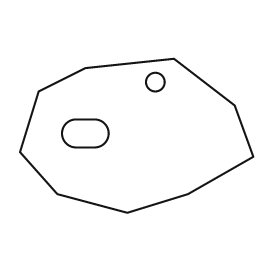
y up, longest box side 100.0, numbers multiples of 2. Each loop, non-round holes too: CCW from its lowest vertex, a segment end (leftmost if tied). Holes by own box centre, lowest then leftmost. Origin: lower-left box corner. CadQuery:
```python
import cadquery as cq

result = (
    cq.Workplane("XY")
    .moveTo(46.0, 0.0)
    .lineTo(72.0, 8.0)
    .lineTo(100.0, 24.0)
    .lineTo(92.0, 46.0)
    .lineTo(66.0, 66.0)
    .lineTo(28.0, 62.0)
    .lineTo(8.0, 52.0)
    .lineTo(0.0, 26.0)
    .lineTo(16.0, 8.0)
    .close()
    .moveTo(24.0, 28.0)
    .lineTo(32.0, 28.0)
    .threePointArc((38.0, 34.0), (32.0, 40.0))
    .lineTo(24.0, 40.0)
    .threePointArc((18.0, 34.0), (24.0, 28.0))
    .close()
    .moveTo(58.0, 56.0)
    .circle(4.0)
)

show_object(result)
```